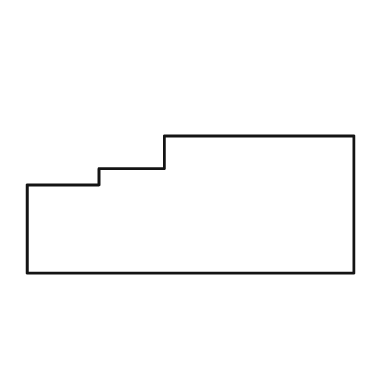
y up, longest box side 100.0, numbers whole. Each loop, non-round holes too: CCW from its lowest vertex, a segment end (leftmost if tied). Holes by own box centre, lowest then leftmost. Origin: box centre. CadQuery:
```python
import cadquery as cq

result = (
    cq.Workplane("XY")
    .moveTo(-50.0, -21.0)
    .lineTo(50.0, -21.0)
    .lineTo(50.0, 21.0)
    .lineTo(-8.0, 21.0)
    .lineTo(-8.0, 11.0)
    .lineTo(-28.0, 11.0)
    .lineTo(-28.0, 6.0)
    .lineTo(-50.0, 6.0)
    .close()
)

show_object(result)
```